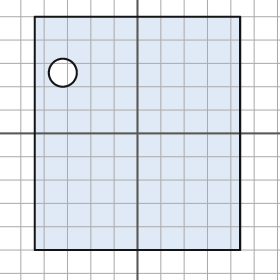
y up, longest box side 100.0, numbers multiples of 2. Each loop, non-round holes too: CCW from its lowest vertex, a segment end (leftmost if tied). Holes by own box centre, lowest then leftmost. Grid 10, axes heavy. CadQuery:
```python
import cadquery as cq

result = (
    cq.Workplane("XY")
    .moveTo(-44.0, -50.0)
    .lineTo(44.0, -50.0)
    .lineTo(44.0, 50.0)
    .lineTo(-44.0, 50.0)
    .close()
    .moveTo(-32.0, 26.0)
    .circle(6.0)
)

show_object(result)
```